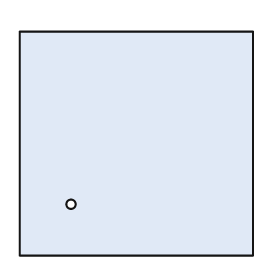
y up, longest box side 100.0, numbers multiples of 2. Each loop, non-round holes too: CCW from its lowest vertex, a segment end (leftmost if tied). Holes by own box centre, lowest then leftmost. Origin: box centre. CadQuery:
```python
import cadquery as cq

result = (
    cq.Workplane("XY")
    .moveTo(-50.0, -48.0)
    .lineTo(50.0, -48.0)
    .lineTo(50.0, 48.0)
    .lineTo(-50.0, 48.0)
    .close()
    .moveTo(-28.0, -26.0)
    .circle(2.0)
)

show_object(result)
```